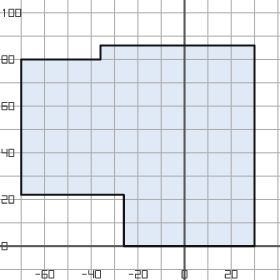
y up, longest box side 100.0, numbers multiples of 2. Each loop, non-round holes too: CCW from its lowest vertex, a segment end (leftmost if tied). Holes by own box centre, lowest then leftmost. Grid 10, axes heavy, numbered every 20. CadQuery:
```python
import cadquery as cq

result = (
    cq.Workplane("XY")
    .moveTo(-26.0, 0.0)
    .lineTo(30.0, 0.0)
    .lineTo(30.0, 86.0)
    .lineTo(-36.0, 86.0)
    .lineTo(-36.0, 80.0)
    .lineTo(-70.0, 80.0)
    .lineTo(-70.0, 22.0)
    .lineTo(-26.0, 22.0)
    .close()
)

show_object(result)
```